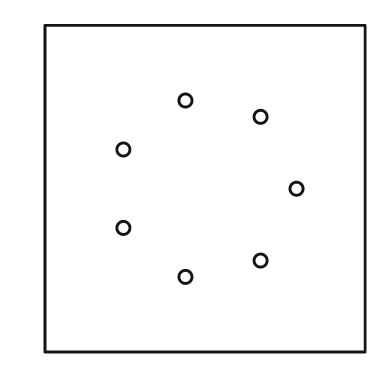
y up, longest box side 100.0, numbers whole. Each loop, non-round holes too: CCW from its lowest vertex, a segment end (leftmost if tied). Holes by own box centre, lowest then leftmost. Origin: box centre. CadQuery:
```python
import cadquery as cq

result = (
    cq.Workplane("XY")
    .moveTo(-49.0, -50.0)
    .lineTo(49.0, -50.0)
    .lineTo(49.0, 50.0)
    .lineTo(-49.0, 50.0)
    .close()
    .moveTo(-6.0, -27.0)
    .circle(2.0)
    .moveTo(17.0, -22.0)
    .circle(2.0)
    .moveTo(-25.0, -12.0)
    .circle(2.0)
    .moveTo(28.0, 0.0)
    .circle(2.0)
    .moveTo(-25.0, 12.0)
    .circle(2.0)
    .moveTo(17.0, 22.0)
    .circle(2.0)
    .moveTo(-6.0, 27.0)
    .circle(2.0)
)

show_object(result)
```